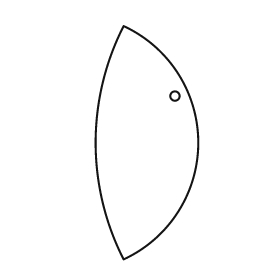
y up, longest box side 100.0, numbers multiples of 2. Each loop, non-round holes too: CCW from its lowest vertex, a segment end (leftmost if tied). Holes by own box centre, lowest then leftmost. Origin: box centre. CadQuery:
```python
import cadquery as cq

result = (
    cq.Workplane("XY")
    .moveTo(-10.0, -50.0)
    .threePointArc((22.0, 0.0), (-10.0, 50.0))
    .threePointArc((-22.0, 0.0), (-10.0, -50.0))
    .close()
    .moveTo(12.0, 20.0)
    .circle(2.0)
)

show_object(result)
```